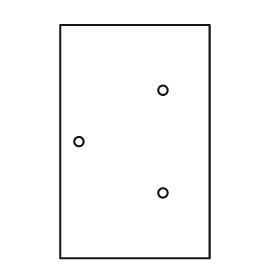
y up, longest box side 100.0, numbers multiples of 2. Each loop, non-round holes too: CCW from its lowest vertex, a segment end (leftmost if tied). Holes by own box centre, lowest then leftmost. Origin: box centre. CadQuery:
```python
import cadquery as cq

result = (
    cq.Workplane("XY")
    .moveTo(-32.0, -50.0)
    .lineTo(32.0, -50.0)
    .lineTo(32.0, 50.0)
    .lineTo(-32.0, 50.0)
    .close()
    .moveTo(12.0, -22.0)
    .circle(2.0)
    .moveTo(-24.0, 0.0)
    .circle(2.0)
    .moveTo(12.0, 22.0)
    .circle(2.0)
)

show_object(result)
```